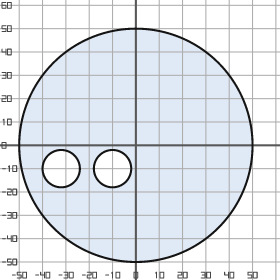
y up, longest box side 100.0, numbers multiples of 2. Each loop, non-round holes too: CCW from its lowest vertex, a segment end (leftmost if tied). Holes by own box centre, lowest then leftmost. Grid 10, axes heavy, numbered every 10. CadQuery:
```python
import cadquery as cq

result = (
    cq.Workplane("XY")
    .moveTo(0.0, 0.0)
    .circle(50.0)
    .moveTo(-32.0, -10.0)
    .circle(8.0)
    .moveTo(-10.0, -10.0)
    .circle(8.0)
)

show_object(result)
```